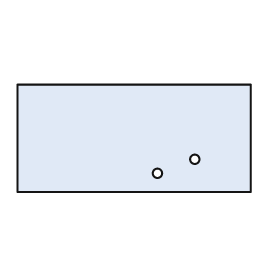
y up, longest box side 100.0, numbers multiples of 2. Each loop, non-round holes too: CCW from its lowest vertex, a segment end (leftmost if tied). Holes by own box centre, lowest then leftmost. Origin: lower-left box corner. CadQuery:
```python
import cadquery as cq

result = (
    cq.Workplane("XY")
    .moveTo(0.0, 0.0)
    .lineTo(100.0, 0.0)
    .lineTo(100.0, 46.0)
    .lineTo(0.0, 46.0)
    .close()
    .moveTo(60.0, 8.0)
    .circle(2.0)
    .moveTo(76.0, 14.0)
    .circle(2.0)
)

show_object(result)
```